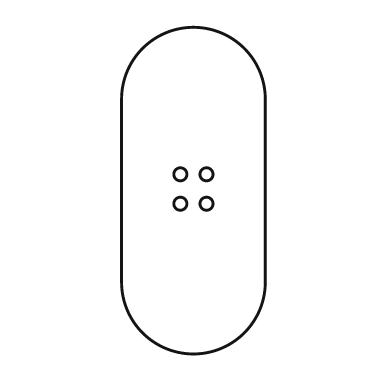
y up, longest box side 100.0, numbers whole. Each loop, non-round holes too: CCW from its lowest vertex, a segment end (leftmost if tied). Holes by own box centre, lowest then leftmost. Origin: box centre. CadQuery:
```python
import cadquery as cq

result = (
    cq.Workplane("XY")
    .moveTo(-22.0, -28.0)
    .threePointArc((0.0, -50.0), (22.0, -28.0))
    .lineTo(22.0, 28.0)
    .threePointArc((0.0, 50.0), (-22.0, 28.0))
    .close()
    .moveTo(-4.0, -4.0)
    .circle(2.0)
    .moveTo(4.0, -4.0)
    .circle(2.0)
    .moveTo(-4.0, 5.0)
    .circle(2.0)
    .moveTo(4.0, 5.0)
    .circle(2.0)
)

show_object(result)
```